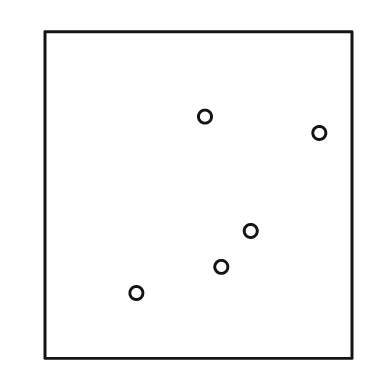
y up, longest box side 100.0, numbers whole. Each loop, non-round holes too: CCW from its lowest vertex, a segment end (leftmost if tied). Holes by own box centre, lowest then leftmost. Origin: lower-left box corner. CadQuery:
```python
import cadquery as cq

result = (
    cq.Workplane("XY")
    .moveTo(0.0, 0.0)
    .lineTo(94.0, 0.0)
    .lineTo(94.0, 100.0)
    .lineTo(0.0, 100.0)
    .close()
    .moveTo(28.0, 20.0)
    .circle(2.0)
    .moveTo(54.0, 28.0)
    .circle(2.0)
    .moveTo(63.0, 39.0)
    .circle(2.0)
    .moveTo(84.0, 69.0)
    .circle(2.0)
    .moveTo(49.0, 74.0)
    .circle(2.0)
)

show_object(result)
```